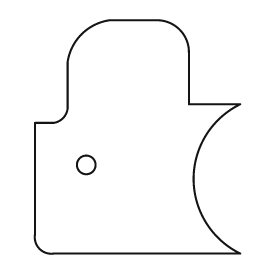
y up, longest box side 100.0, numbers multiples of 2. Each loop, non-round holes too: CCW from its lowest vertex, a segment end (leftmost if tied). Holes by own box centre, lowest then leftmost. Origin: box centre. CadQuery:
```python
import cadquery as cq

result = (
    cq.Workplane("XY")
    .moveTo(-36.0, -50.0)
    .lineTo(44.0, -50.0)
    .threePointArc((24.0, -18.0), (44.0, 14.0))
    .lineTo(22.0, 14.0)
    .lineTo(22.0, 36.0)
    .threePointArc((18.0, 46.0), (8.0, 50.0))
    .lineTo(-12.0, 50.0)
    .threePointArc((-24.0, 44.0), (-30.0, 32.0))
    .lineTo(-30.0, 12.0)
    .threePointArc((-32.0, 8.0), (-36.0, 6.0))
    .lineTo(-44.0, 6.0)
    .lineTo(-44.0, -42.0)
    .threePointArc((-42.0, -48.0), (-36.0, -50.0))
    .close()
    .moveTo(-22.0, -12.0)
    .circle(4.0)
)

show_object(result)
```